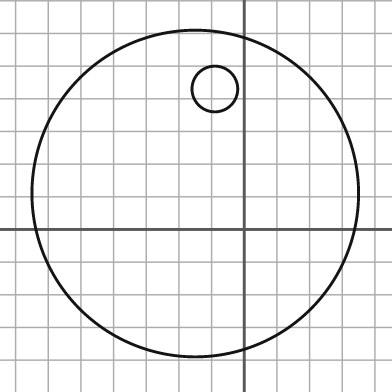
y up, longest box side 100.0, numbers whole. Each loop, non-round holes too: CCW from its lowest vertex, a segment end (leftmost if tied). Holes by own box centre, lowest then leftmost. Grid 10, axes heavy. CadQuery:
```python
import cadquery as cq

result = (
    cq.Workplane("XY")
    .moveTo(-15.0, 11.0)
    .circle(50.0)
    .moveTo(-9.0, 43.0)
    .circle(7.0)
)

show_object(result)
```